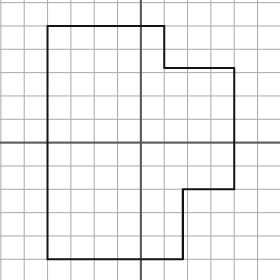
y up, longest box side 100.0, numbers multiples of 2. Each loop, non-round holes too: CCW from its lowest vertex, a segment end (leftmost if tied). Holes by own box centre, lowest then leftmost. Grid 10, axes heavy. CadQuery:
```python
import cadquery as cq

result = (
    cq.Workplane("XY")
    .moveTo(-40.0, -50.0)
    .lineTo(18.0, -50.0)
    .lineTo(18.0, -20.0)
    .lineTo(40.0, -20.0)
    .lineTo(40.0, 32.0)
    .lineTo(10.0, 32.0)
    .lineTo(10.0, 50.0)
    .lineTo(-40.0, 50.0)
    .close()
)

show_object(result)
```